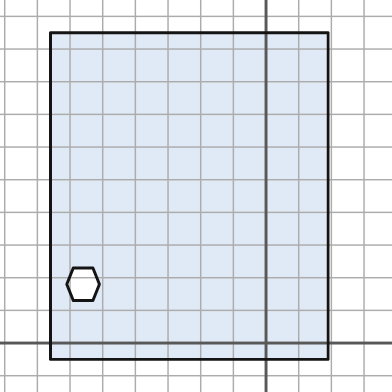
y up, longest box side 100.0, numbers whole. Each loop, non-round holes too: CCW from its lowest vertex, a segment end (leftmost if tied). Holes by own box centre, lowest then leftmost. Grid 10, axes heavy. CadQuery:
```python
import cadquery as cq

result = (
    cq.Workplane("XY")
    .moveTo(-66.0, -5.0)
    .lineTo(19.0, -5.0)
    .lineTo(19.0, 95.0)
    .lineTo(-66.0, 95.0)
    .close()
    .moveTo(-59.0, 13.0)
    .lineTo(-53.0, 13.0)
    .lineTo(-51.0, 18.0)
    .lineTo(-53.0, 23.0)
    .lineTo(-59.0, 23.0)
    .lineTo(-61.0, 18.0)
    .close()
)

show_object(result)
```